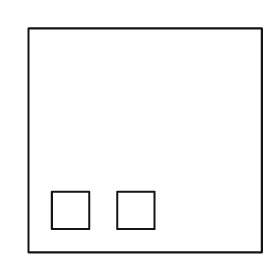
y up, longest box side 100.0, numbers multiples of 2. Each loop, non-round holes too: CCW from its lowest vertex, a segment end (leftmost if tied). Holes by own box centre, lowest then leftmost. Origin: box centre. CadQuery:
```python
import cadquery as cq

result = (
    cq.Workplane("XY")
    .moveTo(-50.0, -48.0)
    .lineTo(50.0, -48.0)
    .lineTo(50.0, 48.0)
    .lineTo(-50.0, 48.0)
    .close()
    .moveTo(-40.0, -38.0)
    .lineTo(-24.0, -38.0)
    .lineTo(-24.0, -22.0)
    .lineTo(-40.0, -22.0)
    .close()
    .moveTo(-12.0, -38.0)
    .lineTo(4.0, -38.0)
    .lineTo(4.0, -22.0)
    .lineTo(-12.0, -22.0)
    .close()
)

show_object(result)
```